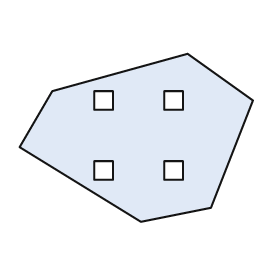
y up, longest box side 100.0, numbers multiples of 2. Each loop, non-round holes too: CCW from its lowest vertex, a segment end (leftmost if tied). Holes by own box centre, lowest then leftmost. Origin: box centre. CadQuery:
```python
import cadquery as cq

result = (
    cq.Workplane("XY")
    .moveTo(2.0, -36.0)
    .lineTo(32.0, -30.0)
    .lineTo(50.0, 16.0)
    .lineTo(22.0, 36.0)
    .lineTo(-36.0, 20.0)
    .lineTo(-50.0, -4.0)
    .close()
    .moveTo(-18.0, -18.0)
    .lineTo(-10.0, -18.0)
    .lineTo(-10.0, -10.0)
    .lineTo(-18.0, -10.0)
    .close()
    .moveTo(12.0, -18.0)
    .lineTo(20.0, -18.0)
    .lineTo(20.0, -10.0)
    .lineTo(12.0, -10.0)
    .close()
    .moveTo(-18.0, 12.0)
    .lineTo(-10.0, 12.0)
    .lineTo(-10.0, 20.0)
    .lineTo(-18.0, 20.0)
    .close()
    .moveTo(12.0, 12.0)
    .lineTo(20.0, 12.0)
    .lineTo(20.0, 20.0)
    .lineTo(12.0, 20.0)
    .close()
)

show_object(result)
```